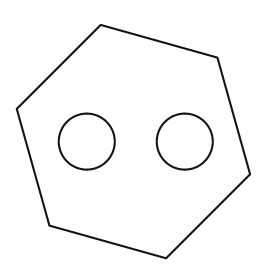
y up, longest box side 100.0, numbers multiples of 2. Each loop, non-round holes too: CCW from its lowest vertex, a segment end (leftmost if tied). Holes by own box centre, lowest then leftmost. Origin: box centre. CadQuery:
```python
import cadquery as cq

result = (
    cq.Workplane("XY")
    .moveTo(14.0, -50.0)
    .lineTo(50.0, -14.0)
    .lineTo(36.0, 36.0)
    .lineTo(-14.0, 50.0)
    .lineTo(-50.0, 14.0)
    .lineTo(-36.0, -36.0)
    .close()
    .moveTo(-20.0, 0.0)
    .circle(12.0)
    .moveTo(22.0, 0.0)
    .circle(12.0)
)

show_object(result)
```